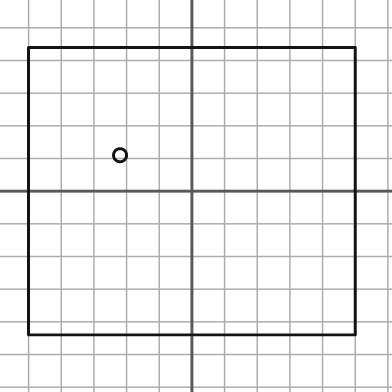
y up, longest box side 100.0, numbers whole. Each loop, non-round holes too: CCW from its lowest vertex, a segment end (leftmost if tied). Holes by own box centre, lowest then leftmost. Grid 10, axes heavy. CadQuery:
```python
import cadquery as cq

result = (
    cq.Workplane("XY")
    .moveTo(-50.0, -44.0)
    .lineTo(50.0, -44.0)
    .lineTo(50.0, 44.0)
    .lineTo(-50.0, 44.0)
    .close()
    .moveTo(-22.0, 11.0)
    .circle(2.0)
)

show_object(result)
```